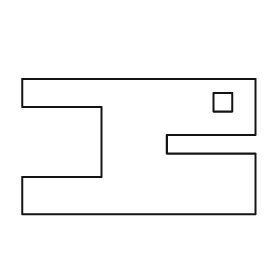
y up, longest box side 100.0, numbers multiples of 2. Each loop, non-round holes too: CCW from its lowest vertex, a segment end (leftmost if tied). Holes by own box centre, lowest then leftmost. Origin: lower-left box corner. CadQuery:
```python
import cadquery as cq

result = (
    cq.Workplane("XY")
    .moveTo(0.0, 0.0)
    .lineTo(100.0, 0.0)
    .lineTo(100.0, 26.0)
    .lineTo(62.0, 26.0)
    .lineTo(62.0, 34.0)
    .lineTo(100.0, 34.0)
    .lineTo(100.0, 58.0)
    .lineTo(0.0, 58.0)
    .lineTo(0.0, 46.0)
    .lineTo(34.0, 46.0)
    .lineTo(34.0, 16.0)
    .lineTo(0.0, 16.0)
    .close()
    .moveTo(82.0, 44.0)
    .lineTo(90.0, 44.0)
    .lineTo(90.0, 52.0)
    .lineTo(82.0, 52.0)
    .close()
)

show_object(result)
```